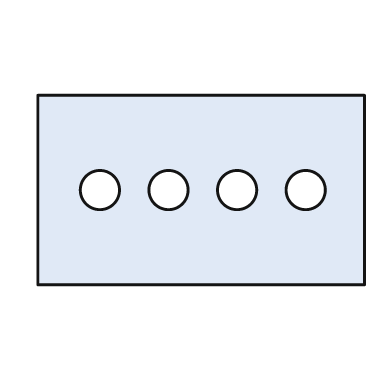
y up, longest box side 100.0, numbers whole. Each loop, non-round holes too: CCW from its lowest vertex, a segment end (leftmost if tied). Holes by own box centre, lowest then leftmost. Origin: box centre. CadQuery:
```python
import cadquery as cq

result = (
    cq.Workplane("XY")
    .moveTo(-50.0, -29.0)
    .lineTo(50.0, -29.0)
    .lineTo(50.0, 29.0)
    .lineTo(-50.0, 29.0)
    .close()
    .moveTo(-31.0, 0.0)
    .circle(6.0)
    .moveTo(-10.0, 0.0)
    .circle(6.0)
    .moveTo(11.0, 0.0)
    .circle(6.0)
    .moveTo(32.0, 0.0)
    .circle(6.0)
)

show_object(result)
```